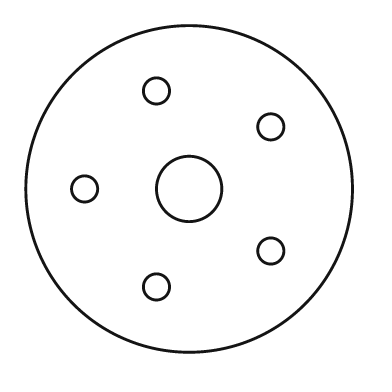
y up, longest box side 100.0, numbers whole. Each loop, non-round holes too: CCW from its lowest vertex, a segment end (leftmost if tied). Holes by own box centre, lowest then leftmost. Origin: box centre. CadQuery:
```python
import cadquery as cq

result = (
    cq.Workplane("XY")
    .moveTo(0.0, 0.0)
    .circle(50.0)
    .moveTo(-10.0, -30.0)
    .circle(4.0)
    .moveTo(25.0, -19.0)
    .circle(4.0)
    .moveTo(-32.0, 0.0)
    .circle(4.0)
    .moveTo(0.0, 0.0)
    .circle(10.0)
    .moveTo(25.0, 19.0)
    .circle(4.0)
    .moveTo(-10.0, 30.0)
    .circle(4.0)
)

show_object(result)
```